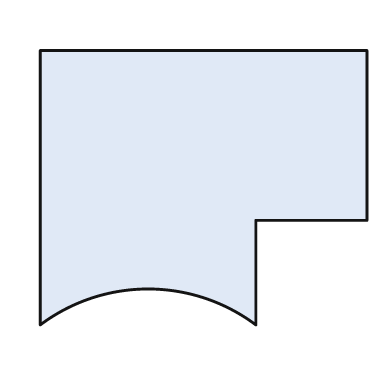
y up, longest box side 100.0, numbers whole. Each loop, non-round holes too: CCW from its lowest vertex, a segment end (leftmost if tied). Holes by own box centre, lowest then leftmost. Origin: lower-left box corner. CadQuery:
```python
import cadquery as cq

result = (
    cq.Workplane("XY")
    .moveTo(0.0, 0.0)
    .threePointArc((33.0, 11.0), (66.0, 0.0))
    .lineTo(66.0, 32.0)
    .lineTo(100.0, 32.0)
    .lineTo(100.0, 84.0)
    .lineTo(0.0, 84.0)
    .close()
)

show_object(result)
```